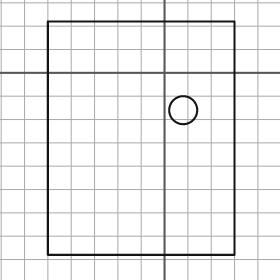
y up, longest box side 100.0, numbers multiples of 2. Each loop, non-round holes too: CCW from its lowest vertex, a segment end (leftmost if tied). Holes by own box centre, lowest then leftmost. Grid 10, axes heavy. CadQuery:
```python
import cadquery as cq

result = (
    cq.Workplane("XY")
    .moveTo(-50.0, -78.0)
    .lineTo(30.0, -78.0)
    .lineTo(30.0, 22.0)
    .lineTo(-50.0, 22.0)
    .close()
    .moveTo(8.0, -16.0)
    .circle(6.0)
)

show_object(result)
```